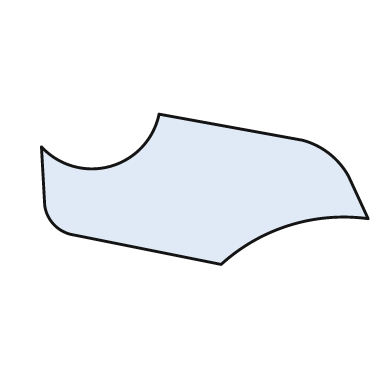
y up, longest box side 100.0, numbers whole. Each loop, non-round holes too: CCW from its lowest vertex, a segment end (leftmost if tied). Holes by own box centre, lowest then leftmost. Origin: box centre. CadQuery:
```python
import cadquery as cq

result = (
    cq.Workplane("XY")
    .moveTo(5.0, -23.0)
    .threePointArc((26.0, -11.0), (50.0, -9.0))
    .lineTo(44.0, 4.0)
    .threePointArc((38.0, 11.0), (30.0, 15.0))
    .lineTo(-14.0, 23.0)
    .threePointArc((-29.0, 7.0), (-50.0, 13.0))
    .lineTo(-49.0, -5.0)
    .threePointArc((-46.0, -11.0), (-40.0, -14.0))
    .close()
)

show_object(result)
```